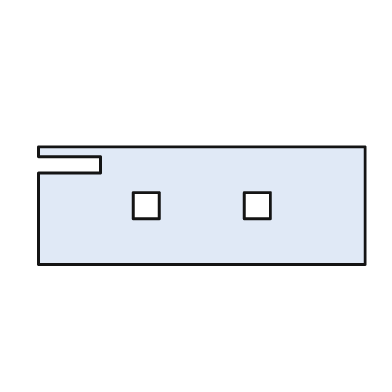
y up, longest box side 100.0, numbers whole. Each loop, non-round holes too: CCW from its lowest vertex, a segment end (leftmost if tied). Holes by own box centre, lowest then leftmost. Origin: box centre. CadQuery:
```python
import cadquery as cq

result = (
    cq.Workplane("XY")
    .moveTo(-50.0, -18.0)
    .lineTo(50.0, -18.0)
    .lineTo(50.0, 18.0)
    .lineTo(-50.0, 18.0)
    .lineTo(-50.0, 15.0)
    .lineTo(-31.0, 15.0)
    .lineTo(-31.0, 10.0)
    .lineTo(-50.0, 10.0)
    .close()
    .moveTo(-21.0, -4.0)
    .lineTo(-13.0, -4.0)
    .lineTo(-13.0, 4.0)
    .lineTo(-21.0, 4.0)
    .close()
    .moveTo(13.0, -4.0)
    .lineTo(21.0, -4.0)
    .lineTo(21.0, 4.0)
    .lineTo(13.0, 4.0)
    .close()
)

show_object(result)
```